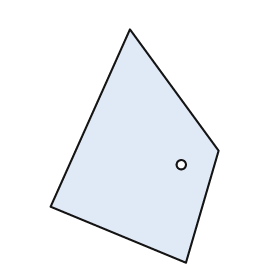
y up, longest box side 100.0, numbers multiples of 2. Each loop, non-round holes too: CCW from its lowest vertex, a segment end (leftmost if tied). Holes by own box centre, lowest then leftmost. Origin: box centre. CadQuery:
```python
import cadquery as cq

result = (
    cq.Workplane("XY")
    .moveTo(22.0, -50.0)
    .lineTo(36.0, -2.0)
    .lineTo(-2.0, 50.0)
    .lineTo(-36.0, -26.0)
    .close()
    .moveTo(20.0, -8.0)
    .circle(2.0)
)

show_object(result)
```